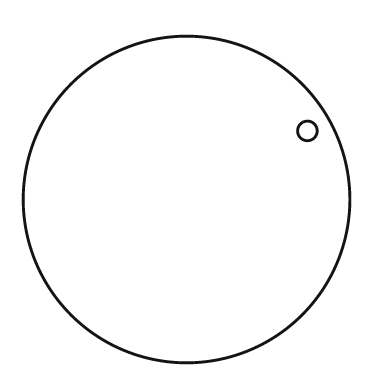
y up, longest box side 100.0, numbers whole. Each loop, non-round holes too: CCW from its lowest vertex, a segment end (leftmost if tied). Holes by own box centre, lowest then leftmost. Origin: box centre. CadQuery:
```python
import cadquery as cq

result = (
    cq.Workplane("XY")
    .moveTo(0.0, 0.0)
    .circle(50.0)
    .moveTo(37.0, 21.0)
    .circle(3.0)
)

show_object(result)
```